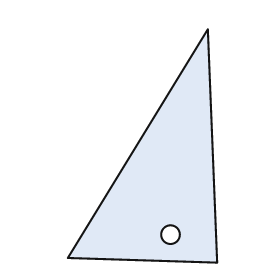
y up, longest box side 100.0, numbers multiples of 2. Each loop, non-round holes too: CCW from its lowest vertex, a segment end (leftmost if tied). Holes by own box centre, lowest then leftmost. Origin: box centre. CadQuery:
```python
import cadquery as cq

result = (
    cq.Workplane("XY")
    .moveTo(32.0, -50.0)
    .lineTo(28.0, 50.0)
    .lineTo(-32.0, -48.0)
    .close()
    .moveTo(12.0, -38.0)
    .circle(4.0)
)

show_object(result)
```